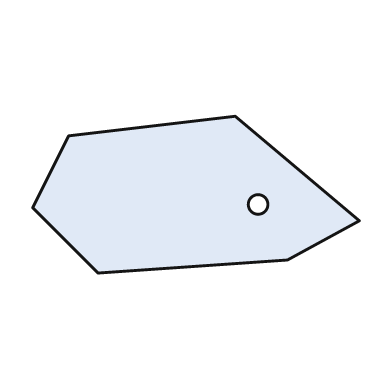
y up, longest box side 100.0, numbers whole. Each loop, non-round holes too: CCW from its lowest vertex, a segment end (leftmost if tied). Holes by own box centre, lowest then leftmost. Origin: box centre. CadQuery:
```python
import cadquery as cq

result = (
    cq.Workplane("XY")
    .moveTo(-30.0, -24.0)
    .lineTo(28.0, -20.0)
    .lineTo(50.0, -8.0)
    .lineTo(12.0, 24.0)
    .lineTo(-39.0, 18.0)
    .lineTo(-50.0, -4.0)
    .close()
    .moveTo(19.0, -3.0)
    .circle(3.0)
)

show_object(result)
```